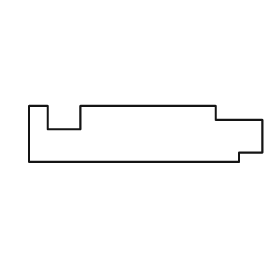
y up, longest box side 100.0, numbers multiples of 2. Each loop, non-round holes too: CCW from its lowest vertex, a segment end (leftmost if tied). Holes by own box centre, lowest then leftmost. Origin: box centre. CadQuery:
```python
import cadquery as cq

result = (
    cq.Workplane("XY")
    .moveTo(-50.0, -12.0)
    .lineTo(40.0, -12.0)
    .lineTo(40.0, -8.0)
    .lineTo(50.0, -8.0)
    .lineTo(50.0, 6.0)
    .lineTo(30.0, 6.0)
    .lineTo(30.0, 12.0)
    .lineTo(-28.0, 12.0)
    .lineTo(-28.0, 2.0)
    .lineTo(-42.0, 2.0)
    .lineTo(-42.0, 12.0)
    .lineTo(-50.0, 12.0)
    .close()
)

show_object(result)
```